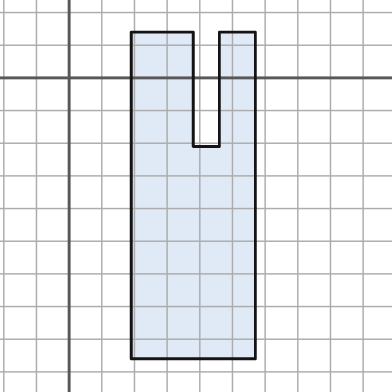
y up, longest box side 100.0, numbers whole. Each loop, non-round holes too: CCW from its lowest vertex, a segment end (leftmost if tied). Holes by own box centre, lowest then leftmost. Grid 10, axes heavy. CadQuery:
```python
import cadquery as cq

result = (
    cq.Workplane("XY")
    .moveTo(19.0, -86.0)
    .lineTo(57.0, -86.0)
    .lineTo(57.0, 14.0)
    .lineTo(46.0, 14.0)
    .lineTo(46.0, -21.0)
    .lineTo(38.0, -21.0)
    .lineTo(38.0, 14.0)
    .lineTo(19.0, 14.0)
    .close()
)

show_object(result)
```